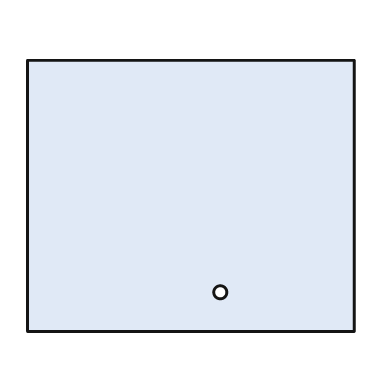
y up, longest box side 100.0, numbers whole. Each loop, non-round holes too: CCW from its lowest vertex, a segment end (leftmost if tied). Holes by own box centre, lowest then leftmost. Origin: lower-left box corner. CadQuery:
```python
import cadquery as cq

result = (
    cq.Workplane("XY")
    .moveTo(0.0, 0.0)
    .lineTo(100.0, 0.0)
    .lineTo(100.0, 83.0)
    .lineTo(0.0, 83.0)
    .close()
    .moveTo(59.0, 12.0)
    .circle(2.0)
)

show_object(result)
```